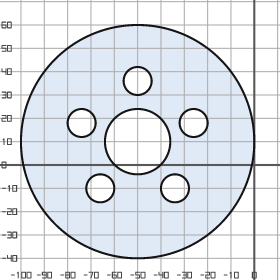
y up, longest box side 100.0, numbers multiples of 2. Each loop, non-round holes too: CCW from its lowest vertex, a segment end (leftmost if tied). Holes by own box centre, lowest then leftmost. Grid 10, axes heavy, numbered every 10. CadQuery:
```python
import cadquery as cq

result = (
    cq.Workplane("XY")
    .moveTo(-50.0, 10.0)
    .circle(50.0)
    .moveTo(-66.0, -10.0)
    .circle(6.0)
    .moveTo(-34.0, -10.0)
    .circle(6.0)
    .moveTo(-50.0, 10.0)
    .circle(14.0)
    .moveTo(-74.0, 18.0)
    .circle(6.0)
    .moveTo(-26.0, 18.0)
    .circle(6.0)
    .moveTo(-50.0, 36.0)
    .circle(6.0)
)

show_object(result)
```